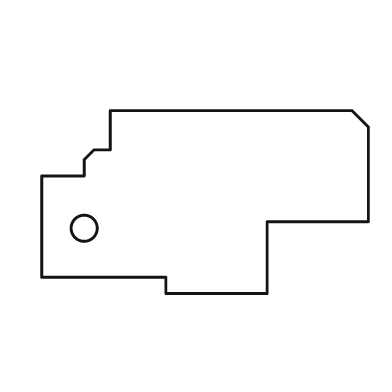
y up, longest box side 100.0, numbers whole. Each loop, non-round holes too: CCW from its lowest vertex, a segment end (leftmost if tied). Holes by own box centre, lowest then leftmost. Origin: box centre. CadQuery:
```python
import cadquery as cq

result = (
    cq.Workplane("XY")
    .moveTo(-12.0, -28.0)
    .lineTo(19.0, -28.0)
    .lineTo(19.0, -6.0)
    .lineTo(50.0, -6.0)
    .lineTo(50.0, 23.0)
    .lineTo(45.0, 28.0)
    .lineTo(-29.0, 28.0)
    .lineTo(-29.0, 16.0)
    .lineTo(-34.0, 16.0)
    .lineTo(-37.0, 13.0)
    .lineTo(-37.0, 8.0)
    .lineTo(-50.0, 8.0)
    .lineTo(-50.0, -23.0)
    .lineTo(-12.0, -23.0)
    .close()
    .moveTo(-37.0, -8.0)
    .circle(4.0)
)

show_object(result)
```